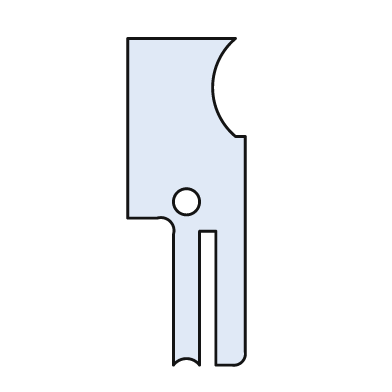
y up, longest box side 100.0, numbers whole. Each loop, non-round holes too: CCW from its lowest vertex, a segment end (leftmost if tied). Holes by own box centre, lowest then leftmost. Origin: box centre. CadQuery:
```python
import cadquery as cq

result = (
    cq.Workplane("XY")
    .moveTo(-4.0, -50.0)
    .threePointArc((0.0, -48.0), (4.0, -50.0))
    .lineTo(4.0, -9.0)
    .lineTo(9.0, -9.0)
    .lineTo(9.0, -50.0)
    .lineTo(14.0, -50.0)
    .threePointArc((17.0, -49.0), (18.0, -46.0))
    .lineTo(18.0, 20.0)
    .lineTo(15.0, 20.0)
    .threePointArc((8.0, 35.0), (15.0, 50.0))
    .lineTo(-18.0, 50.0)
    .lineTo(-18.0, -5.0)
    .lineTo(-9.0, -5.0)
    .threePointArc((-5.0, -6.0), (-4.0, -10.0))
    .close()
    .moveTo(0.0, 0.0)
    .circle(4.0)
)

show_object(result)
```